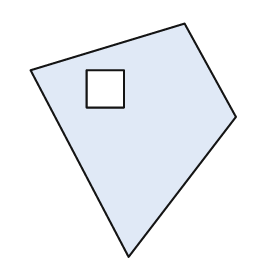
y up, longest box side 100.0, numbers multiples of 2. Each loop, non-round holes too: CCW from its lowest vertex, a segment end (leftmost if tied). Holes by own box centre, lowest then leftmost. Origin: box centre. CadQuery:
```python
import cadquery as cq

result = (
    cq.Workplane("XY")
    .moveTo(-2.0, -50.0)
    .lineTo(44.0, 10.0)
    .lineTo(22.0, 50.0)
    .lineTo(-44.0, 30.0)
    .close()
    .moveTo(-20.0, 14.0)
    .lineTo(-4.0, 14.0)
    .lineTo(-4.0, 30.0)
    .lineTo(-20.0, 30.0)
    .close()
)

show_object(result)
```